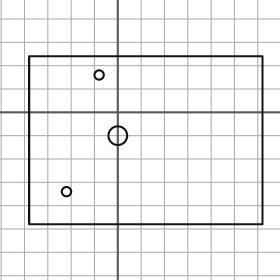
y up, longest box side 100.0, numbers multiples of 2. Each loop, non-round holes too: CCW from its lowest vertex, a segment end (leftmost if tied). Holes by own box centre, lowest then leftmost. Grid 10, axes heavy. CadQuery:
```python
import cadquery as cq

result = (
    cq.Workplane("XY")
    .moveTo(-38.0, -48.0)
    .lineTo(62.0, -48.0)
    .lineTo(62.0, 24.0)
    .lineTo(-38.0, 24.0)
    .close()
    .moveTo(-22.0, -34.0)
    .circle(2.0)
    .moveTo(0.0, -10.0)
    .circle(4.0)
    .moveTo(-8.0, 16.0)
    .circle(2.0)
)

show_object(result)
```